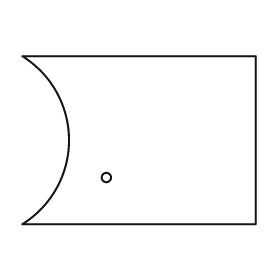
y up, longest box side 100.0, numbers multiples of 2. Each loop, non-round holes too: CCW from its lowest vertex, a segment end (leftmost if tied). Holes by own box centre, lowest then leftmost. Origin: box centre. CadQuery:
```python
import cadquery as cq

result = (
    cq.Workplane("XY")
    .moveTo(-50.0, -36.0)
    .lineTo(50.0, -36.0)
    .lineTo(50.0, 36.0)
    .lineTo(-50.0, 36.0)
    .threePointArc((-30.0, 0.0), (-50.0, -36.0))
    .close()
    .moveTo(-14.0, -16.0)
    .circle(2.0)
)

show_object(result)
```